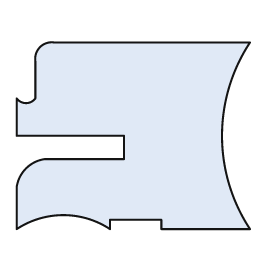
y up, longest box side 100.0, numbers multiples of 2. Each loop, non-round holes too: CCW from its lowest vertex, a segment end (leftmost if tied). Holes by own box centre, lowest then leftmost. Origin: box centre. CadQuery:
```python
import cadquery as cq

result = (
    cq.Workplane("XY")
    .moveTo(-50.0, -40.0)
    .threePointArc((-30.0, -34.0), (-10.0, -40.0))
    .lineTo(-10.0, -36.0)
    .lineTo(12.0, -36.0)
    .lineTo(12.0, -40.0)
    .lineTo(50.0, -40.0)
    .threePointArc((38.0, 0.0), (50.0, 40.0))
    .lineTo(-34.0, 40.0)
    .threePointArc((-40.0, 38.0), (-42.0, 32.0))
    .lineTo(-42.0, 16.0)
    .threePointArc((-46.0, 14.0), (-50.0, 16.0))
    .lineTo(-50.0, 0.0)
    .lineTo(-4.0, 0.0)
    .lineTo(-4.0, -10.0)
    .lineTo(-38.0, -10.0)
    .threePointArc((-46.0, -14.0), (-50.0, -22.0))
    .close()
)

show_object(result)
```